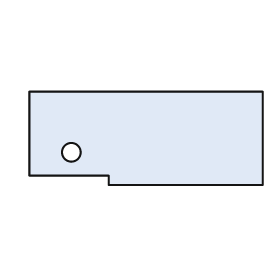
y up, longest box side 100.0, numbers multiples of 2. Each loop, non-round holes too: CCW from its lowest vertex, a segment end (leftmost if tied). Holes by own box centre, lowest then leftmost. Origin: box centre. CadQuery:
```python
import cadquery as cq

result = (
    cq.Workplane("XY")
    .moveTo(-16.0, -20.0)
    .lineTo(50.0, -20.0)
    .lineTo(50.0, 20.0)
    .lineTo(-50.0, 20.0)
    .lineTo(-50.0, -16.0)
    .lineTo(-16.0, -16.0)
    .close()
    .moveTo(-32.0, -6.0)
    .circle(4.0)
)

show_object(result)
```